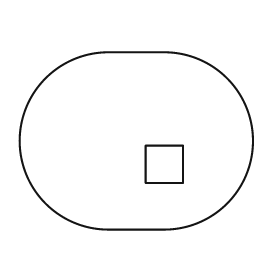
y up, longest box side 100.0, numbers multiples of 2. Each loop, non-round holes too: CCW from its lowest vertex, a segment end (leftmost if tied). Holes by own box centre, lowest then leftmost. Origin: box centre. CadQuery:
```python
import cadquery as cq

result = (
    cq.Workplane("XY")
    .moveTo(-12.0, -38.0)
    .lineTo(12.0, -38.0)
    .threePointArc((50.0, 0.0), (12.0, 38.0))
    .lineTo(-12.0, 38.0)
    .threePointArc((-50.0, 0.0), (-12.0, -38.0))
    .close()
    .moveTo(4.0, -18.0)
    .lineTo(20.0, -18.0)
    .lineTo(20.0, -2.0)
    .lineTo(4.0, -2.0)
    .close()
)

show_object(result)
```